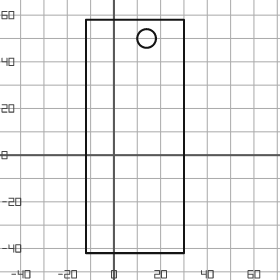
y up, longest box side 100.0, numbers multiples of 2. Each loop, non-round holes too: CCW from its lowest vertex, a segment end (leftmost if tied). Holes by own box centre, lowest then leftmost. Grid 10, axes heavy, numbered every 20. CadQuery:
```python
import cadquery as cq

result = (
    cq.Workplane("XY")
    .moveTo(-12.0, -42.0)
    .lineTo(30.0, -42.0)
    .lineTo(30.0, 58.0)
    .lineTo(-12.0, 58.0)
    .close()
    .moveTo(14.0, 50.0)
    .circle(4.0)
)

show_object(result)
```